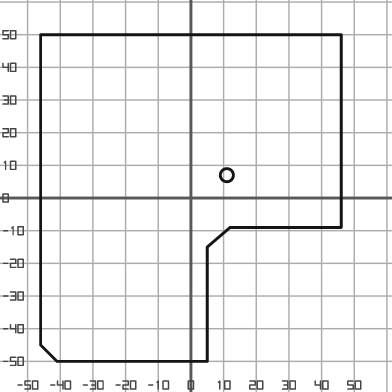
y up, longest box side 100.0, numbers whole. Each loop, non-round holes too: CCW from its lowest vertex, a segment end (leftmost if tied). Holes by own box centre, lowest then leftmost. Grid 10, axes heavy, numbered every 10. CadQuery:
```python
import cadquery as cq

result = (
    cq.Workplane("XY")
    .moveTo(-41.0, -50.0)
    .lineTo(5.0, -50.0)
    .lineTo(5.0, -15.0)
    .lineTo(12.0, -9.0)
    .lineTo(46.0, -9.0)
    .lineTo(46.0, 50.0)
    .lineTo(-46.0, 50.0)
    .lineTo(-46.0, -45.0)
    .close()
    .moveTo(11.0, 7.0)
    .circle(2.0)
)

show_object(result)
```